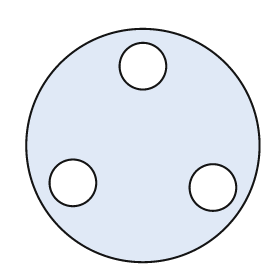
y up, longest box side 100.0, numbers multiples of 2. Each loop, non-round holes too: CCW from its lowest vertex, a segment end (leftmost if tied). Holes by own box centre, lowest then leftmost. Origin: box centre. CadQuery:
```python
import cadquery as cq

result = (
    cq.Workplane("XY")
    .moveTo(0.0, 0.0)
    .circle(50.0)
    .moveTo(30.0, -18.0)
    .circle(10.0)
    .moveTo(-30.0, -16.0)
    .circle(10.0)
    .moveTo(0.0, 34.0)
    .circle(10.0)
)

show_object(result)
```